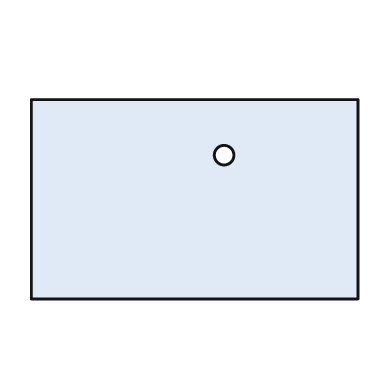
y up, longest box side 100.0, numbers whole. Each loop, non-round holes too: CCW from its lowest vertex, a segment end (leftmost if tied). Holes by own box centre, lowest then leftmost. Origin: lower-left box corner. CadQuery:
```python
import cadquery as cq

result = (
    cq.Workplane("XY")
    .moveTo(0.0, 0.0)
    .lineTo(100.0, 0.0)
    .lineTo(100.0, 61.0)
    .lineTo(0.0, 61.0)
    .close()
    .moveTo(59.0, 44.0)
    .circle(3.0)
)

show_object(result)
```